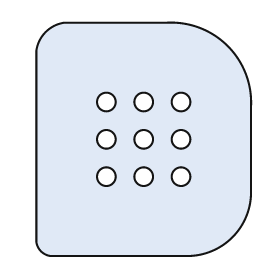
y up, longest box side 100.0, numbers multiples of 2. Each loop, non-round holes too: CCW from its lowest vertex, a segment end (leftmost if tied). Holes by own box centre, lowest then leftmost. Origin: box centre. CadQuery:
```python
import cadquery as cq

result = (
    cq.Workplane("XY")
    .moveTo(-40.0, -50.0)
    .lineTo(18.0, -50.0)
    .threePointArc((38.0, -42.0), (46.0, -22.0))
    .lineTo(46.0, 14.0)
    .threePointArc((36.0, 40.0), (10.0, 50.0))
    .lineTo(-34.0, 50.0)
    .threePointArc((-42.0, 46.0), (-46.0, 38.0))
    .lineTo(-46.0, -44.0)
    .threePointArc((-44.0, -48.0), (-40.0, -50.0))
    .close()
    .moveTo(-16.0, -16.0)
    .circle(4.0)
    .moveTo(0.0, -16.0)
    .circle(4.0)
    .moveTo(16.0, -16.0)
    .circle(4.0)
    .moveTo(-16.0, 0.0)
    .circle(4.0)
    .moveTo(0.0, 0.0)
    .circle(4.0)
    .moveTo(16.0, 0.0)
    .circle(4.0)
    .moveTo(-16.0, 16.0)
    .circle(4.0)
    .moveTo(0.0, 16.0)
    .circle(4.0)
    .moveTo(16.0, 16.0)
    .circle(4.0)
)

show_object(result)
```